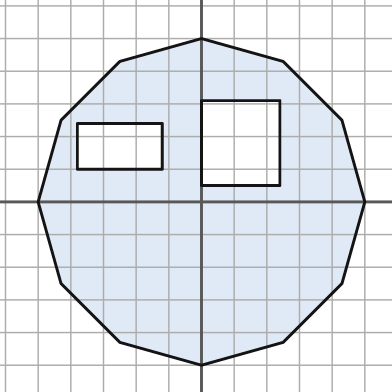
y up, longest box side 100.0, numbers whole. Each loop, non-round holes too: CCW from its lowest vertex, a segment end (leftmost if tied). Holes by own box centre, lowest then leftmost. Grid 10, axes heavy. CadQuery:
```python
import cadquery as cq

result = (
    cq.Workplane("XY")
    .moveTo(0.0, -50.0)
    .lineTo(25.0, -43.0)
    .lineTo(43.0, -25.0)
    .lineTo(50.0, 0.0)
    .lineTo(43.0, 25.0)
    .lineTo(25.0, 43.0)
    .lineTo(0.0, 50.0)
    .lineTo(-25.0, 43.0)
    .lineTo(-43.0, 25.0)
    .lineTo(-50.0, 0.0)
    .lineTo(-43.0, -25.0)
    .lineTo(-25.0, -43.0)
    .close()
    .moveTo(-38.0, 10.0)
    .lineTo(-12.0, 10.0)
    .lineTo(-12.0, 24.0)
    .lineTo(-38.0, 24.0)
    .close()
    .moveTo(0.0, 5.0)
    .lineTo(24.0, 5.0)
    .lineTo(24.0, 31.0)
    .lineTo(0.0, 31.0)
    .close()
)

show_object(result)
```